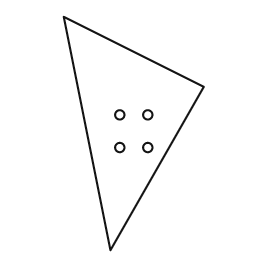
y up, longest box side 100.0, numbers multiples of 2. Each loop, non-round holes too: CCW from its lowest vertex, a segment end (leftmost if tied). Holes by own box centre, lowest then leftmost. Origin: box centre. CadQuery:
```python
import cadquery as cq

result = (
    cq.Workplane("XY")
    .moveTo(-10.0, -50.0)
    .lineTo(30.0, 20.0)
    .lineTo(-30.0, 50.0)
    .close()
    .moveTo(-6.0, -6.0)
    .circle(2.0)
    .moveTo(6.0, -6.0)
    .circle(2.0)
    .moveTo(-6.0, 8.0)
    .circle(2.0)
    .moveTo(6.0, 8.0)
    .circle(2.0)
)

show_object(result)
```